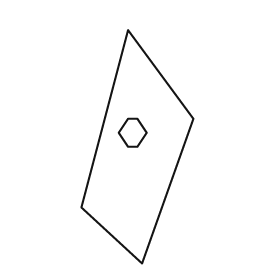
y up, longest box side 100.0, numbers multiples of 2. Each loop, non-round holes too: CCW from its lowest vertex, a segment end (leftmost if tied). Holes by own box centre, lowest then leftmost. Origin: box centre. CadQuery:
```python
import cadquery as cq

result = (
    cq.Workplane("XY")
    .moveTo(2.0, -50.0)
    .lineTo(24.0, 12.0)
    .lineTo(-4.0, 50.0)
    .lineTo(-24.0, -26.0)
    .close()
    .moveTo(-4.0, 0.0)
    .lineTo(0.0, 0.0)
    .lineTo(4.0, 6.0)
    .lineTo(0.0, 12.0)
    .lineTo(-4.0, 12.0)
    .lineTo(-8.0, 6.0)
    .close()
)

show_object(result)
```